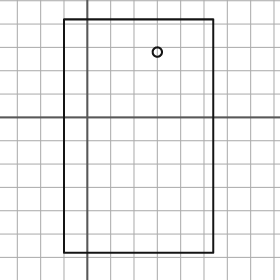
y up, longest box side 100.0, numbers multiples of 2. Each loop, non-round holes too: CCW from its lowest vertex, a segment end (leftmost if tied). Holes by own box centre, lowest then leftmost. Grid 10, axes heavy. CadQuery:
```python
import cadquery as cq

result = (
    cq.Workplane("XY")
    .moveTo(-10.0, -58.0)
    .lineTo(54.0, -58.0)
    .lineTo(54.0, 42.0)
    .lineTo(-10.0, 42.0)
    .close()
    .moveTo(30.0, 28.0)
    .circle(2.0)
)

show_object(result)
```